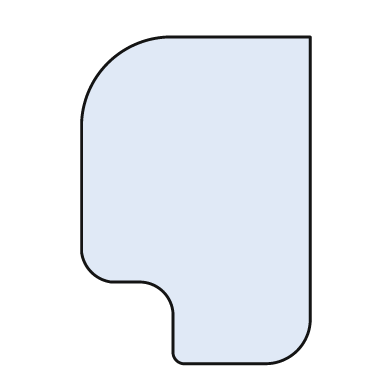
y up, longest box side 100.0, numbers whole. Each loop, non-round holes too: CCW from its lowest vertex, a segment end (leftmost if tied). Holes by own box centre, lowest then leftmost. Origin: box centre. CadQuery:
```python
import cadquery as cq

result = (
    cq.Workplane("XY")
    .moveTo(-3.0, -50.0)
    .lineTo(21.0, -50.0)
    .threePointArc((31.0, -46.0), (35.0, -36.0))
    .lineTo(35.0, 50.0)
    .lineTo(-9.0, 50.0)
    .threePointArc((-27.0, 42.0), (-35.0, 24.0))
    .lineTo(-35.0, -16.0)
    .threePointArc((-32.0, -22.0), (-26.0, -25.0))
    .lineTo(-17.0, -25.0)
    .threePointArc((-10.0, -28.0), (-7.0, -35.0))
    .lineTo(-7.0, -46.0)
    .threePointArc((-6.0, -49.0), (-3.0, -50.0))
    .close()
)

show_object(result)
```